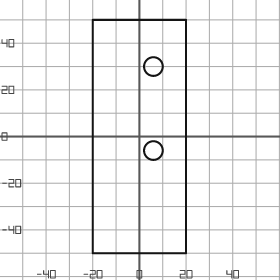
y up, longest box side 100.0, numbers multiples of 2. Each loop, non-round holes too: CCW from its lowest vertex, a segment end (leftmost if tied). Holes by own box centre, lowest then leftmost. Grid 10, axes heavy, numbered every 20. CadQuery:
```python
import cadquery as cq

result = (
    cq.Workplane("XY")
    .moveTo(-20.0, -50.0)
    .lineTo(20.0, -50.0)
    .lineTo(20.0, 50.0)
    .lineTo(-20.0, 50.0)
    .close()
    .moveTo(6.0, -6.0)
    .circle(4.0)
    .moveTo(6.0, 30.0)
    .circle(4.0)
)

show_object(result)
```